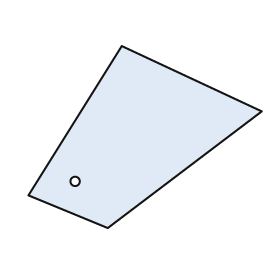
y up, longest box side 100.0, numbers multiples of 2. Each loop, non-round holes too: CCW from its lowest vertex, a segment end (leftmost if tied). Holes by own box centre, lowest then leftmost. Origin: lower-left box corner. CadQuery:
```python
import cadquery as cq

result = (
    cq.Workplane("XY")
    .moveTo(34.0, 0.0)
    .lineTo(100.0, 50.0)
    .lineTo(40.0, 78.0)
    .lineTo(0.0, 14.0)
    .close()
    .moveTo(20.0, 20.0)
    .circle(2.0)
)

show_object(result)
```